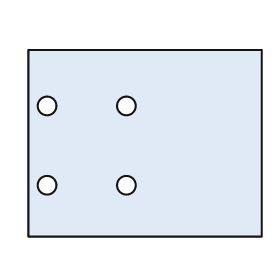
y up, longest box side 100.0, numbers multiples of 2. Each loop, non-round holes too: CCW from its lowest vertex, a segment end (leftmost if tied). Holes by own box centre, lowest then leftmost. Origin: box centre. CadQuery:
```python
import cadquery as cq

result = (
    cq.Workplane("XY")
    .moveTo(-50.0, -40.0)
    .lineTo(50.0, -40.0)
    .lineTo(50.0, 40.0)
    .lineTo(-50.0, 40.0)
    .close()
    .moveTo(-42.0, -18.0)
    .circle(4.0)
    .moveTo(-8.0, -18.0)
    .circle(4.0)
    .moveTo(-42.0, 16.0)
    .circle(4.0)
    .moveTo(-8.0, 16.0)
    .circle(4.0)
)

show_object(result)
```